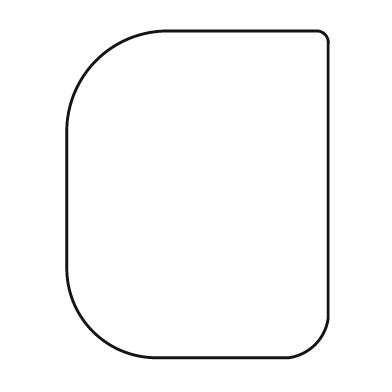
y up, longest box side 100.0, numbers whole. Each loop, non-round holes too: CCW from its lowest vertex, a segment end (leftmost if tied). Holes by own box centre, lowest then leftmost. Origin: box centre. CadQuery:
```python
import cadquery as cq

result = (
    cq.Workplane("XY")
    .moveTo(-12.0, -50.0)
    .lineTo(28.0, -50.0)
    .threePointArc((36.0, -46.0), (40.0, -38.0))
    .lineTo(40.0, 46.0)
    .threePointArc((39.0, 49.0), (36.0, 50.0))
    .lineTo(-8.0, 50.0)
    .threePointArc((-31.0, 41.0), (-40.0, 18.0))
    .lineTo(-40.0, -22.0)
    .threePointArc((-32.0, -42.0), (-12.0, -50.0))
    .close()
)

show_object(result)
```